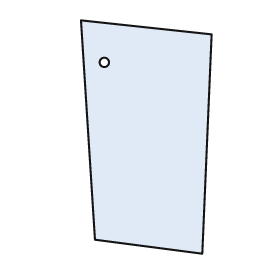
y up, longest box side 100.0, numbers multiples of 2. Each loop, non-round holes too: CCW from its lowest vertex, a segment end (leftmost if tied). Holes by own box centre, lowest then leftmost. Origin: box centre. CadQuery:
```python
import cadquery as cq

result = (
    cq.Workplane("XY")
    .moveTo(24.0, -50.0)
    .lineTo(28.0, 44.0)
    .lineTo(-28.0, 50.0)
    .lineTo(-22.0, -44.0)
    .close()
    .moveTo(-18.0, 32.0)
    .circle(2.0)
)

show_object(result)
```